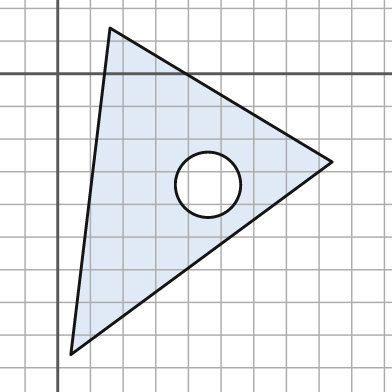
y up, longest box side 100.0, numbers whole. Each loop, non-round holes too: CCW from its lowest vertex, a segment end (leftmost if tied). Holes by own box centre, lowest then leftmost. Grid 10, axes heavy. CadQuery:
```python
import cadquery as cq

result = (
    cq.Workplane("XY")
    .moveTo(4.0, -86.0)
    .lineTo(84.0, -27.0)
    .lineTo(16.0, 14.0)
    .close()
    .moveTo(46.0, -34.0)
    .circle(10.0)
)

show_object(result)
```